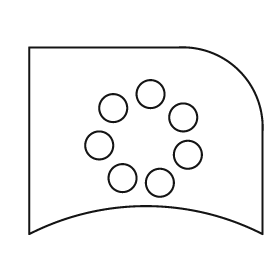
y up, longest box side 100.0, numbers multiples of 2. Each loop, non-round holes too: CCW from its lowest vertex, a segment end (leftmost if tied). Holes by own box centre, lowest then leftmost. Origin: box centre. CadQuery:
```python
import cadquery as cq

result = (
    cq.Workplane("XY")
    .moveTo(-50.0, -40.0)
    .threePointArc((0.0, -28.0), (50.0, -40.0))
    .lineTo(50.0, 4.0)
    .threePointArc((40.0, 30.0), (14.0, 40.0))
    .lineTo(-50.0, 40.0)
    .close()
    .moveTo(6.0, -18.0)
    .circle(6.0)
    .moveTo(-10.0, -16.0)
    .circle(6.0)
    .moveTo(18.0, -6.0)
    .circle(6.0)
    .moveTo(-20.0, -2.0)
    .circle(6.0)
    .moveTo(16.0, 10.0)
    .circle(6.0)
    .moveTo(-14.0, 14.0)
    .circle(6.0)
    .moveTo(2.0, 20.0)
    .circle(6.0)
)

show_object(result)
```